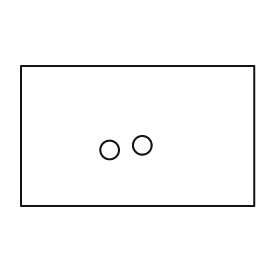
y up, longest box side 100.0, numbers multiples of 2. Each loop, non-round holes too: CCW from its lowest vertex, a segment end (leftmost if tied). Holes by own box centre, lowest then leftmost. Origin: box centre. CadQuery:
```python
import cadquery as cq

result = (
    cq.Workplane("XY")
    .moveTo(-50.0, -30.0)
    .lineTo(50.0, -30.0)
    .lineTo(50.0, 30.0)
    .lineTo(-50.0, 30.0)
    .close()
    .moveTo(-12.0, -6.0)
    .circle(4.0)
    .moveTo(2.0, -4.0)
    .circle(4.0)
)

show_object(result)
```